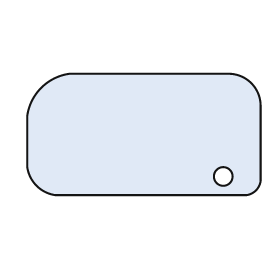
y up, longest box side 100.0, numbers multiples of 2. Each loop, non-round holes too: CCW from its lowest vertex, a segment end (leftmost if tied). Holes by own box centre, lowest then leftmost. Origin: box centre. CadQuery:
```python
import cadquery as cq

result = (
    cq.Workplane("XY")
    .moveTo(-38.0, -26.0)
    .lineTo(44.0, -26.0)
    .threePointArc((48.0, -24.0), (50.0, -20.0))
    .lineTo(50.0, 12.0)
    .threePointArc((46.0, 22.0), (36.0, 26.0))
    .lineTo(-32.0, 26.0)
    .threePointArc((-44.0, 20.0), (-50.0, 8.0))
    .lineTo(-50.0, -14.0)
    .threePointArc((-46.0, -22.0), (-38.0, -26.0))
    .close()
    .moveTo(34.0, -18.0)
    .circle(4.0)
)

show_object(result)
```